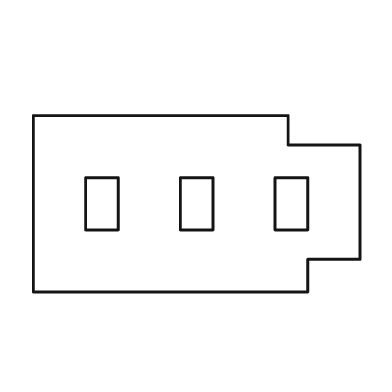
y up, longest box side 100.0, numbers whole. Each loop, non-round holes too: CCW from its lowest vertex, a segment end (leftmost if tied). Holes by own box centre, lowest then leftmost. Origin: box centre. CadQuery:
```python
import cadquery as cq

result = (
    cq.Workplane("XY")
    .moveTo(-50.0, -27.0)
    .lineTo(34.0, -27.0)
    .lineTo(34.0, -17.0)
    .lineTo(50.0, -17.0)
    .lineTo(50.0, 18.0)
    .lineTo(28.0, 18.0)
    .lineTo(28.0, 27.0)
    .lineTo(-50.0, 27.0)
    .close()
    .moveTo(-34.0, -8.0)
    .lineTo(-24.0, -8.0)
    .lineTo(-24.0, 8.0)
    .lineTo(-34.0, 8.0)
    .close()
    .moveTo(-5.0, -8.0)
    .lineTo(5.0, -8.0)
    .lineTo(5.0, 8.0)
    .lineTo(-5.0, 8.0)
    .close()
    .moveTo(24.0, -8.0)
    .lineTo(34.0, -8.0)
    .lineTo(34.0, 8.0)
    .lineTo(24.0, 8.0)
    .close()
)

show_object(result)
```